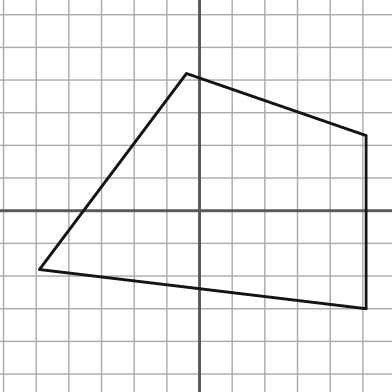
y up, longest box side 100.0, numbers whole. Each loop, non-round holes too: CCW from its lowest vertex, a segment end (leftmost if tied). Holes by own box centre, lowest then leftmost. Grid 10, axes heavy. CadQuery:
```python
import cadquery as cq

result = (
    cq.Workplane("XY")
    .moveTo(51.0, -30.0)
    .lineTo(51.0, 23.0)
    .lineTo(-4.0, 42.0)
    .lineTo(-49.0, -18.0)
    .close()
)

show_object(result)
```